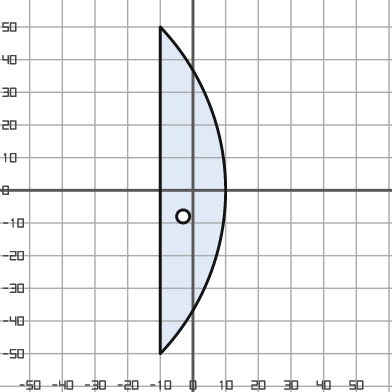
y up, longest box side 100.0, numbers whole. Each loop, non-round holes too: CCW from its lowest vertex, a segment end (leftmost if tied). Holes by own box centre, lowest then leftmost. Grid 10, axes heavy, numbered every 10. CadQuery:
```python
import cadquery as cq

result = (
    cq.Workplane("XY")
    .moveTo(-10.0, -50.0)
    .threePointArc((10.0, 0.0), (-10.0, 50.0))
    .close()
    .moveTo(-3.0, -8.0)
    .circle(2.0)
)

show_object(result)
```